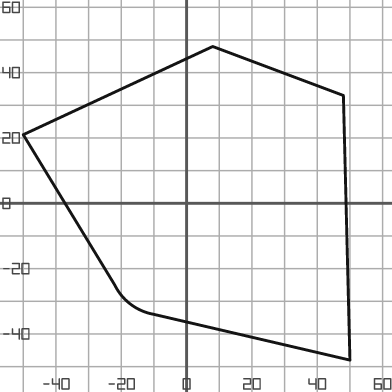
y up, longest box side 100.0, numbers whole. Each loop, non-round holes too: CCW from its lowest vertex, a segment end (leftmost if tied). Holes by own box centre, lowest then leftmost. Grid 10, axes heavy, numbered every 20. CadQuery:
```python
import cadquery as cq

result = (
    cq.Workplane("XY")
    .moveTo(50.0, -48.0)
    .lineTo(48.0, 33.0)
    .lineTo(8.0, 48.0)
    .lineTo(-50.0, 21.0)
    .lineTo(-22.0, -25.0)
    .threePointArc((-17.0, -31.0), (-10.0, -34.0))
    .close()
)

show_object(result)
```